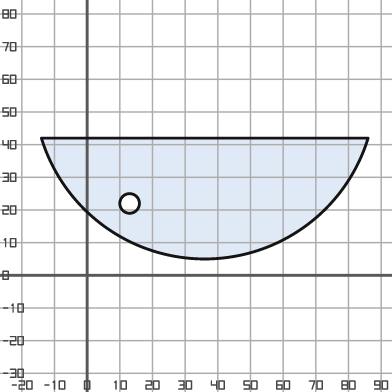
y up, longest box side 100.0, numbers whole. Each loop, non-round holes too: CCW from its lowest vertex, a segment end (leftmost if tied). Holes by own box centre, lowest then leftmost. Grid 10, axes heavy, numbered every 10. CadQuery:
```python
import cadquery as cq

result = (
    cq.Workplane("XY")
    .moveTo(-14.0, 42.0)
    .threePointArc((36.0, 5.0), (86.0, 42.0))
    .close()
    .moveTo(13.0, 22.0)
    .circle(3.0)
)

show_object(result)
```